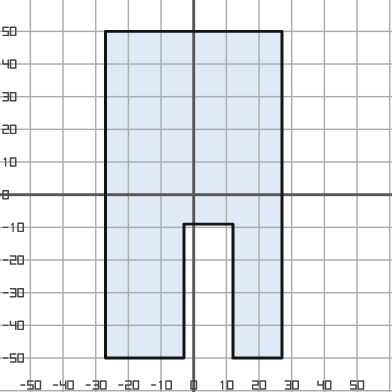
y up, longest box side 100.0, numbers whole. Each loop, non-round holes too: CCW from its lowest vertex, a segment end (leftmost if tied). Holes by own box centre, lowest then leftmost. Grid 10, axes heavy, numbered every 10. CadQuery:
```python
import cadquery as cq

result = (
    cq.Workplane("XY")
    .moveTo(-27.0, -50.0)
    .lineTo(-3.0, -50.0)
    .lineTo(-3.0, -9.0)
    .lineTo(12.0, -9.0)
    .lineTo(12.0, -50.0)
    .lineTo(27.0, -50.0)
    .lineTo(27.0, 50.0)
    .lineTo(-27.0, 50.0)
    .close()
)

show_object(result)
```